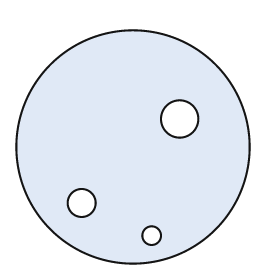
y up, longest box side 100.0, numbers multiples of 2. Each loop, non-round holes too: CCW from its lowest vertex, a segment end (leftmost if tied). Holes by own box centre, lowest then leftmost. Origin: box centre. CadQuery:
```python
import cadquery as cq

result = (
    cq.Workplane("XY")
    .moveTo(0.0, 0.0)
    .circle(50.0)
    .moveTo(8.0, -38.0)
    .circle(4.0)
    .moveTo(-22.0, -24.0)
    .circle(6.0)
    .moveTo(20.0, 12.0)
    .circle(8.0)
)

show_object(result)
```